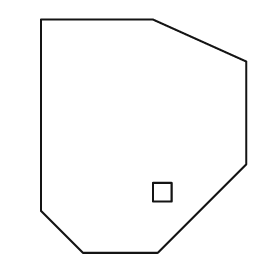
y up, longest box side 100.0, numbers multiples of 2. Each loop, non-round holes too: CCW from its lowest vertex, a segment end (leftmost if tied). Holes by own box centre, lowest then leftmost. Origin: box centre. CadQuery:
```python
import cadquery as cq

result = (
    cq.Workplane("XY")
    .moveTo(-26.0, -50.0)
    .lineTo(6.0, -50.0)
    .lineTo(44.0, -12.0)
    .lineTo(44.0, 32.0)
    .lineTo(4.0, 50.0)
    .lineTo(-44.0, 50.0)
    .lineTo(-44.0, -32.0)
    .close()
    .moveTo(4.0, -28.0)
    .lineTo(12.0, -28.0)
    .lineTo(12.0, -20.0)
    .lineTo(4.0, -20.0)
    .close()
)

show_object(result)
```